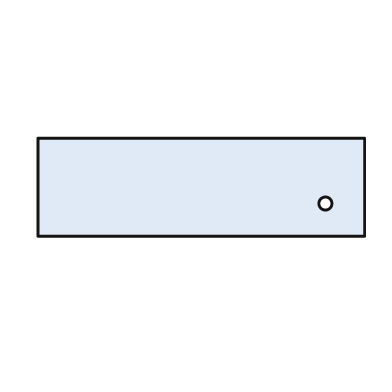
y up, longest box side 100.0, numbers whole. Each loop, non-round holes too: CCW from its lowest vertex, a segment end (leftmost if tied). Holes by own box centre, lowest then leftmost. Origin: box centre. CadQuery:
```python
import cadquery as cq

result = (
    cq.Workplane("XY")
    .moveTo(-50.0, -15.0)
    .lineTo(50.0, -15.0)
    .lineTo(50.0, 15.0)
    .lineTo(-50.0, 15.0)
    .close()
    .moveTo(38.0, -5.0)
    .circle(2.0)
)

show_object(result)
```